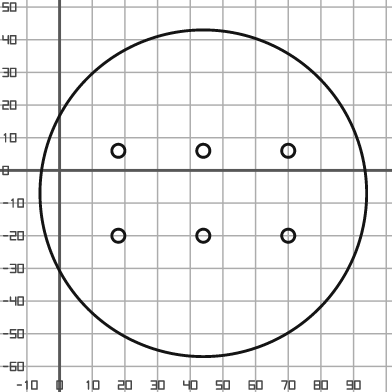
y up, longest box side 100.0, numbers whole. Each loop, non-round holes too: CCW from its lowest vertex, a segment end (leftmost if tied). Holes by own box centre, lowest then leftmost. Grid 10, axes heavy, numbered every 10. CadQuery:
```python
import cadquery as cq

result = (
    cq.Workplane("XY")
    .moveTo(44.0, -7.0)
    .circle(50.0)
    .moveTo(18.0, -20.0)
    .circle(2.0)
    .moveTo(44.0, -20.0)
    .circle(2.0)
    .moveTo(70.0, -20.0)
    .circle(2.0)
    .moveTo(18.0, 6.0)
    .circle(2.0)
    .moveTo(44.0, 6.0)
    .circle(2.0)
    .moveTo(70.0, 6.0)
    .circle(2.0)
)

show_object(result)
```